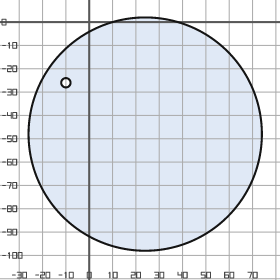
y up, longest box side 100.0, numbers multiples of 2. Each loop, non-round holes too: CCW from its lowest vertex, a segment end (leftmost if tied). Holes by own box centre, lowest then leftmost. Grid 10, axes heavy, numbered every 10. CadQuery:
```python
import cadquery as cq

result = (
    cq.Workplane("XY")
    .moveTo(24.0, -48.0)
    .circle(50.0)
    .moveTo(-10.0, -26.0)
    .circle(2.0)
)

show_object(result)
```